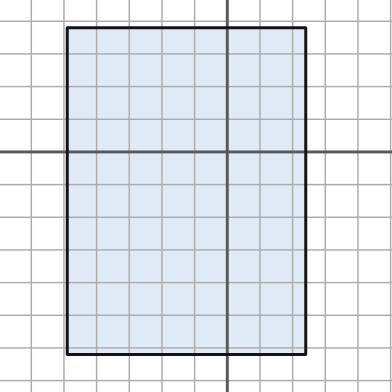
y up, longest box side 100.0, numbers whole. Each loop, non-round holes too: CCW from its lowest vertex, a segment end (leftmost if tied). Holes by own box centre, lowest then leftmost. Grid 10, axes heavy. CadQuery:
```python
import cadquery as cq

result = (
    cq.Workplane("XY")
    .moveTo(-49.0, -62.0)
    .lineTo(24.0, -62.0)
    .lineTo(24.0, 38.0)
    .lineTo(-49.0, 38.0)
    .close()
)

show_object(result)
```